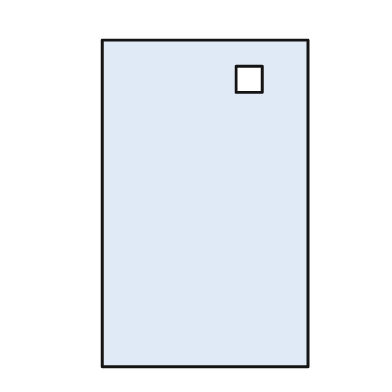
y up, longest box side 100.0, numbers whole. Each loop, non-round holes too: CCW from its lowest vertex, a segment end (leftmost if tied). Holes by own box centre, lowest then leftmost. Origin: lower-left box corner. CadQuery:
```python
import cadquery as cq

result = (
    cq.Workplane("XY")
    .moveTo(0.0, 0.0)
    .lineTo(63.0, 0.0)
    .lineTo(63.0, 100.0)
    .lineTo(0.0, 100.0)
    .close()
    .moveTo(41.0, 84.0)
    .lineTo(49.0, 84.0)
    .lineTo(49.0, 92.0)
    .lineTo(41.0, 92.0)
    .close()
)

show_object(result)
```